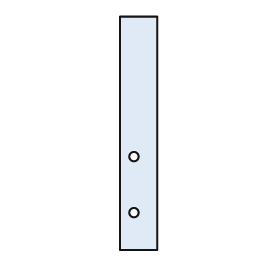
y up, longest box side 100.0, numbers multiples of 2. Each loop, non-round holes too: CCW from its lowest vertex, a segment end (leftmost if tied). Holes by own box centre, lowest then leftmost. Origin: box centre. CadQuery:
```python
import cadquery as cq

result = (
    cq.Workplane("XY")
    .moveTo(-8.0, -50.0)
    .lineTo(8.0, -50.0)
    .lineTo(8.0, 50.0)
    .lineTo(-8.0, 50.0)
    .close()
    .moveTo(-2.0, -34.0)
    .circle(2.0)
    .moveTo(-2.0, -10.0)
    .circle(2.0)
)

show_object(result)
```